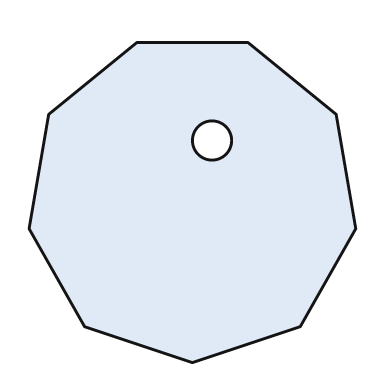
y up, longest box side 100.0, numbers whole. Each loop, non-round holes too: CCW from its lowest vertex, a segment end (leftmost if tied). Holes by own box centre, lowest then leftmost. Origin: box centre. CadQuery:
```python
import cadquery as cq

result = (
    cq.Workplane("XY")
    .moveTo(0.0, -49.0)
    .lineTo(33.0, -38.0)
    .lineTo(50.0, -8.0)
    .lineTo(44.0, 27.0)
    .lineTo(17.0, 49.0)
    .lineTo(-17.0, 49.0)
    .lineTo(-44.0, 27.0)
    .lineTo(-50.0, -8.0)
    .lineTo(-33.0, -38.0)
    .close()
    .moveTo(6.0, 19.0)
    .circle(6.0)
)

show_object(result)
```